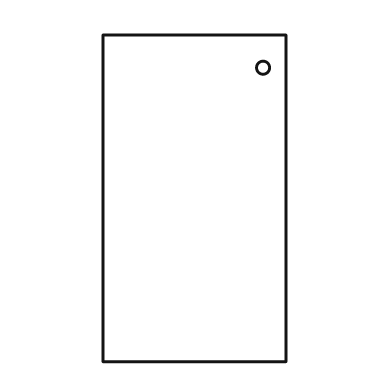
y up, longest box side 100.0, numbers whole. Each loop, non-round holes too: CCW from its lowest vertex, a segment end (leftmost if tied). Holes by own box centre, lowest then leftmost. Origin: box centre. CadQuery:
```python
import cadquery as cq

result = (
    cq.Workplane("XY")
    .moveTo(-28.0, -50.0)
    .lineTo(28.0, -50.0)
    .lineTo(28.0, 50.0)
    .lineTo(-28.0, 50.0)
    .close()
    .moveTo(21.0, 40.0)
    .circle(2.0)
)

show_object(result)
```